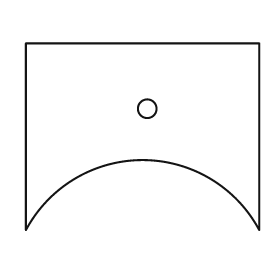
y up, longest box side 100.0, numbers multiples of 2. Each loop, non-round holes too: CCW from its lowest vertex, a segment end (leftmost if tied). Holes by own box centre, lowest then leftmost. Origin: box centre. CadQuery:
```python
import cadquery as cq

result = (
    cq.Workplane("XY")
    .moveTo(-50.0, -40.0)
    .threePointArc((0.0, -10.0), (50.0, -40.0))
    .lineTo(50.0, 40.0)
    .lineTo(-50.0, 40.0)
    .close()
    .moveTo(2.0, 12.0)
    .circle(4.0)
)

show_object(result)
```